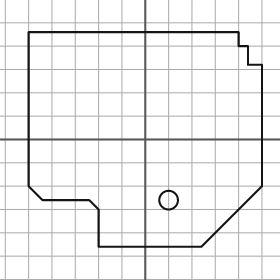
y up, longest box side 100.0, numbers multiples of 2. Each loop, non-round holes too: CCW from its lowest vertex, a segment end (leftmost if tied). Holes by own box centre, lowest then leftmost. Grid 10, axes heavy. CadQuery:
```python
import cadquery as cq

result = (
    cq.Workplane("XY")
    .moveTo(-20.0, -46.0)
    .lineTo(24.0, -46.0)
    .lineTo(50.0, -20.0)
    .lineTo(50.0, 32.0)
    .lineTo(44.0, 32.0)
    .lineTo(44.0, 40.0)
    .lineTo(40.0, 40.0)
    .lineTo(40.0, 46.0)
    .lineTo(-50.0, 46.0)
    .lineTo(-50.0, -20.0)
    .lineTo(-44.0, -26.0)
    .lineTo(-24.0, -26.0)
    .lineTo(-20.0, -30.0)
    .close()
    .moveTo(10.0, -26.0)
    .circle(4.0)
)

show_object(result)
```